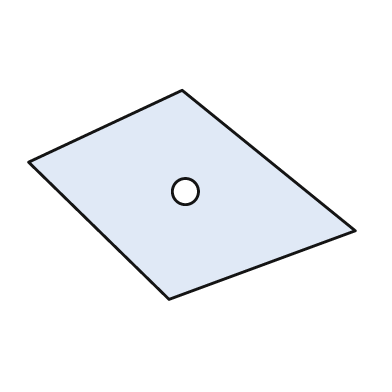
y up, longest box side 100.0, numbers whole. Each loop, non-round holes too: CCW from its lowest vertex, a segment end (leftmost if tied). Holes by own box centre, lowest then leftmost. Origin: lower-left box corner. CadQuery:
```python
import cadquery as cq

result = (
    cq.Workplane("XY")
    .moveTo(43.0, 0.0)
    .lineTo(100.0, 21.0)
    .lineTo(47.0, 64.0)
    .lineTo(0.0, 42.0)
    .close()
    .moveTo(48.0, 33.0)
    .circle(4.0)
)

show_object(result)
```